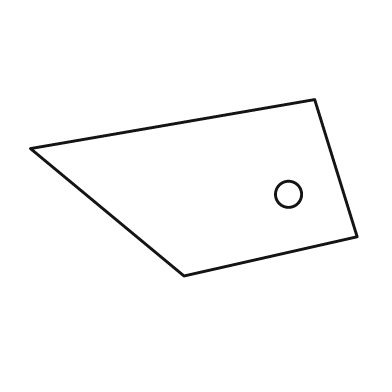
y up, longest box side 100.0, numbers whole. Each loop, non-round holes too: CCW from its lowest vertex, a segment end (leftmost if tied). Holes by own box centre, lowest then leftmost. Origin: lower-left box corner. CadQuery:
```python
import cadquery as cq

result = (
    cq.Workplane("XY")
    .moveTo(47.0, 0.0)
    .lineTo(100.0, 12.0)
    .lineTo(87.0, 54.0)
    .lineTo(0.0, 39.0)
    .close()
    .moveTo(79.0, 25.0)
    .circle(4.0)
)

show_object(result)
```